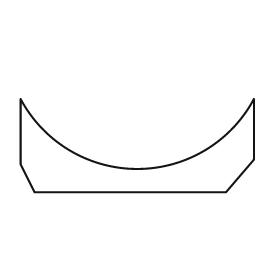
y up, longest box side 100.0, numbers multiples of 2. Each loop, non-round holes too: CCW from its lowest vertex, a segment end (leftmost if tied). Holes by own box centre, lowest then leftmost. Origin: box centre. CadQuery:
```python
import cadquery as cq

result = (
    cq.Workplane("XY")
    .moveTo(-44.0, -20.0)
    .lineTo(38.0, -20.0)
    .lineTo(50.0, -6.0)
    .lineTo(50.0, 20.0)
    .threePointArc((0.0, -10.0), (-50.0, 20.0))
    .lineTo(-50.0, -8.0)
    .close()
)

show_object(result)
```